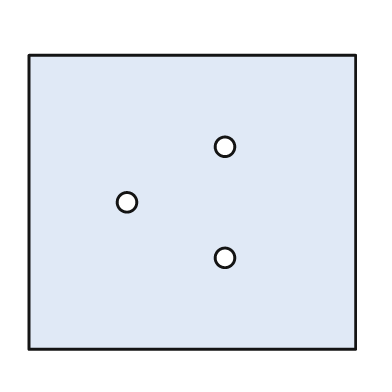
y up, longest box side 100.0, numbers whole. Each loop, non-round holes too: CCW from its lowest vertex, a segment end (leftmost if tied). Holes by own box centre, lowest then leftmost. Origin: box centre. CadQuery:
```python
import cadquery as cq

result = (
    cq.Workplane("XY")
    .moveTo(-50.0, -45.0)
    .lineTo(50.0, -45.0)
    .lineTo(50.0, 45.0)
    .lineTo(-50.0, 45.0)
    .close()
    .moveTo(10.0, -17.0)
    .circle(3.0)
    .moveTo(-20.0, 0.0)
    .circle(3.0)
    .moveTo(10.0, 17.0)
    .circle(3.0)
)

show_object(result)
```